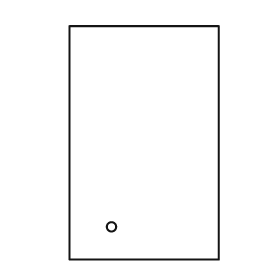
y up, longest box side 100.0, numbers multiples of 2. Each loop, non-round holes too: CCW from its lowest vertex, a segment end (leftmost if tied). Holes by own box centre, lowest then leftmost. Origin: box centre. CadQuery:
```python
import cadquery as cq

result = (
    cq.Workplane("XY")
    .moveTo(-32.0, -50.0)
    .lineTo(32.0, -50.0)
    .lineTo(32.0, 50.0)
    .lineTo(-32.0, 50.0)
    .close()
    .moveTo(-14.0, -36.0)
    .circle(2.0)
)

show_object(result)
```